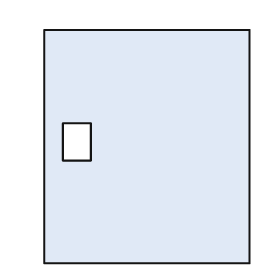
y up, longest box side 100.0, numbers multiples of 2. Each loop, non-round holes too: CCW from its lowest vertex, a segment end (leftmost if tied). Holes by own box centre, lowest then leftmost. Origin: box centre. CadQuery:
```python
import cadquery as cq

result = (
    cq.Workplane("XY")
    .moveTo(-44.0, -50.0)
    .lineTo(44.0, -50.0)
    .lineTo(44.0, 50.0)
    .lineTo(-44.0, 50.0)
    .close()
    .moveTo(-36.0, -6.0)
    .lineTo(-24.0, -6.0)
    .lineTo(-24.0, 10.0)
    .lineTo(-36.0, 10.0)
    .close()
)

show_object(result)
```